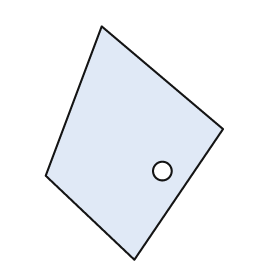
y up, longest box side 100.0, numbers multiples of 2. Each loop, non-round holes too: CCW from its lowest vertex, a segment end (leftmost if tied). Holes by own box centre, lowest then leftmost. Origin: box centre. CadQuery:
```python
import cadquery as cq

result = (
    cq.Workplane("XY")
    .moveTo(0.0, -50.0)
    .lineTo(38.0, 6.0)
    .lineTo(-14.0, 50.0)
    .lineTo(-38.0, -14.0)
    .close()
    .moveTo(12.0, -12.0)
    .circle(4.0)
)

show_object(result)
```